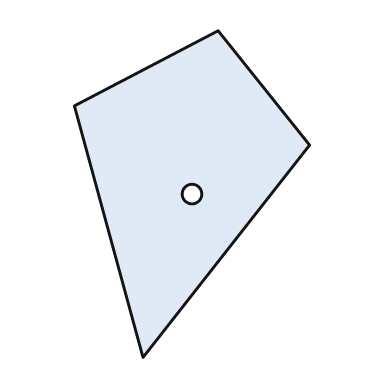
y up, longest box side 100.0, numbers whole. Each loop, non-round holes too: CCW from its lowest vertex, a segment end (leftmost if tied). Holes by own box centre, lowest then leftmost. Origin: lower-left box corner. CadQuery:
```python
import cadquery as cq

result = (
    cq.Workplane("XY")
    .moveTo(21.0, 0.0)
    .lineTo(72.0, 65.0)
    .lineTo(44.0, 100.0)
    .lineTo(0.0, 77.0)
    .close()
    .moveTo(36.0, 50.0)
    .circle(3.0)
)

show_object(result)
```